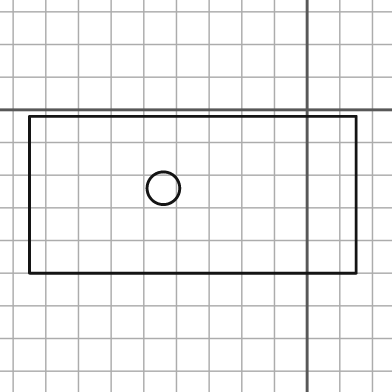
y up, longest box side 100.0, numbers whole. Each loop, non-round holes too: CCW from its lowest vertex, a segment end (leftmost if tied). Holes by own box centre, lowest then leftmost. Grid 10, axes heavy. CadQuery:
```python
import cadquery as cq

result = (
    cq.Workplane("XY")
    .moveTo(-85.0, -50.0)
    .lineTo(15.0, -50.0)
    .lineTo(15.0, -2.0)
    .lineTo(-85.0, -2.0)
    .close()
    .moveTo(-44.0, -24.0)
    .circle(5.0)
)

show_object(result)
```